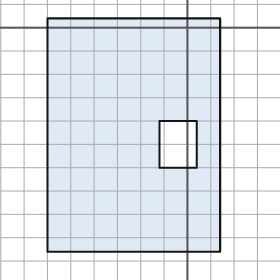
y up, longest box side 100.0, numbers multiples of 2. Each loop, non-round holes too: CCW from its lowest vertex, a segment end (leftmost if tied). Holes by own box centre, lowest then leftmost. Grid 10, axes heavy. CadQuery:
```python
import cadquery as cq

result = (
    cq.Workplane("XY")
    .moveTo(-60.0, -96.0)
    .lineTo(14.0, -96.0)
    .lineTo(14.0, 4.0)
    .lineTo(-60.0, 4.0)
    .close()
    .moveTo(-12.0, -60.0)
    .lineTo(4.0, -60.0)
    .lineTo(4.0, -40.0)
    .lineTo(-12.0, -40.0)
    .close()
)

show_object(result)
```